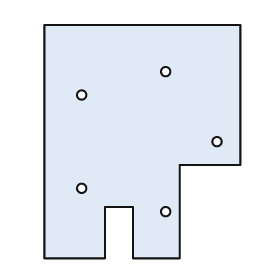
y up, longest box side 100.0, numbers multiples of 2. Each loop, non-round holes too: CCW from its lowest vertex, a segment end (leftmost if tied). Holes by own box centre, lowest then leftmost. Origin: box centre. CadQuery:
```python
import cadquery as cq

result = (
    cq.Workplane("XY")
    .moveTo(-42.0, -50.0)
    .lineTo(-16.0, -50.0)
    .lineTo(-16.0, -28.0)
    .lineTo(-4.0, -28.0)
    .lineTo(-4.0, -50.0)
    .lineTo(16.0, -50.0)
    .lineTo(16.0, -10.0)
    .lineTo(42.0, -10.0)
    .lineTo(42.0, 50.0)
    .lineTo(-42.0, 50.0)
    .close()
    .moveTo(10.0, -30.0)
    .circle(2.0)
    .moveTo(-26.0, -20.0)
    .circle(2.0)
    .moveTo(32.0, 0.0)
    .circle(2.0)
    .moveTo(-26.0, 20.0)
    .circle(2.0)
    .moveTo(10.0, 30.0)
    .circle(2.0)
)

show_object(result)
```